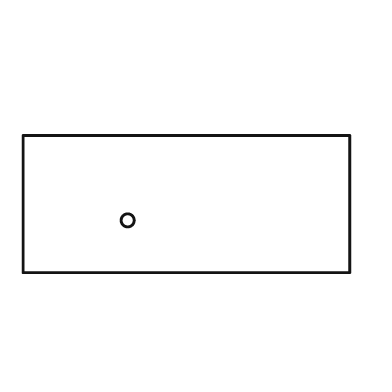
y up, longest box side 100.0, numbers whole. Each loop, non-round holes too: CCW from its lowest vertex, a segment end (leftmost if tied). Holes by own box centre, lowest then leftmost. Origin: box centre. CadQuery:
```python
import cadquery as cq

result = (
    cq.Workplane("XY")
    .moveTo(-50.0, -21.0)
    .lineTo(50.0, -21.0)
    .lineTo(50.0, 21.0)
    .lineTo(-50.0, 21.0)
    .close()
    .moveTo(-18.0, -5.0)
    .circle(2.0)
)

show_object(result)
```